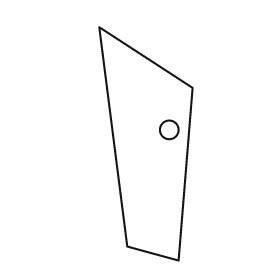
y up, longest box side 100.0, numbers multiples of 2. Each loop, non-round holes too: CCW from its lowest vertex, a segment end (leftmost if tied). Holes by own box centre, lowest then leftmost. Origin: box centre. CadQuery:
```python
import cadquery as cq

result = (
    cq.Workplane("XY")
    .moveTo(14.0, -50.0)
    .lineTo(20.0, 24.0)
    .lineTo(-20.0, 50.0)
    .lineTo(-8.0, -44.0)
    .close()
    .moveTo(10.0, 6.0)
    .circle(4.0)
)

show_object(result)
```